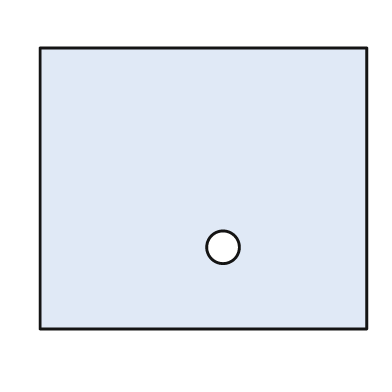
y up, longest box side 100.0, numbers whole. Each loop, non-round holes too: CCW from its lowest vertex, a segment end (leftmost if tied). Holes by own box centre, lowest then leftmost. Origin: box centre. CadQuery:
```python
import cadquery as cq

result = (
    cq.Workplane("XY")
    .moveTo(-50.0, -43.0)
    .lineTo(50.0, -43.0)
    .lineTo(50.0, 43.0)
    .lineTo(-50.0, 43.0)
    .close()
    .moveTo(6.0, -18.0)
    .circle(5.0)
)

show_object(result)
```